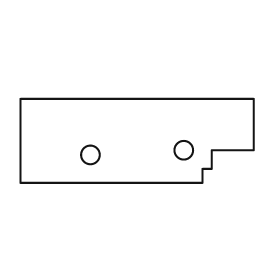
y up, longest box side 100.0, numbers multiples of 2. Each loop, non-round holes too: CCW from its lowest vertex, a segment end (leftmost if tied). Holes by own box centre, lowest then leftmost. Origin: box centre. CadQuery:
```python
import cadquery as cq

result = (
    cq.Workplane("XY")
    .moveTo(-50.0, -18.0)
    .lineTo(28.0, -18.0)
    .lineTo(28.0, -12.0)
    .lineTo(32.0, -12.0)
    .lineTo(32.0, -4.0)
    .lineTo(50.0, -4.0)
    .lineTo(50.0, 18.0)
    .lineTo(-50.0, 18.0)
    .close()
    .moveTo(-20.0, -6.0)
    .circle(4.0)
    .moveTo(20.0, -4.0)
    .circle(4.0)
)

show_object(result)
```